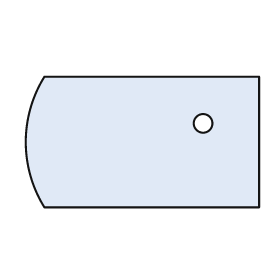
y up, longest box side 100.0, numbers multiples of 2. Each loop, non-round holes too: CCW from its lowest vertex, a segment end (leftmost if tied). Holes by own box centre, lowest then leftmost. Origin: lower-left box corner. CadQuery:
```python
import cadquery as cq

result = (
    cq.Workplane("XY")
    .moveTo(8.0, 0.0)
    .lineTo(100.0, 0.0)
    .lineTo(100.0, 56.0)
    .lineTo(8.0, 56.0)
    .threePointArc((0.0, 28.0), (8.0, 0.0))
    .close()
    .moveTo(76.0, 36.0)
    .circle(4.0)
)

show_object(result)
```